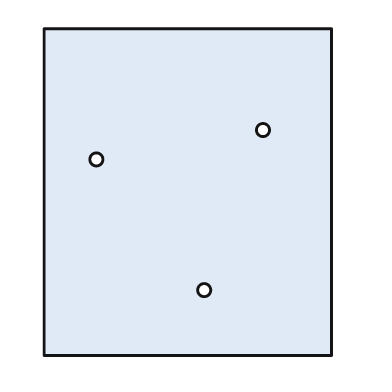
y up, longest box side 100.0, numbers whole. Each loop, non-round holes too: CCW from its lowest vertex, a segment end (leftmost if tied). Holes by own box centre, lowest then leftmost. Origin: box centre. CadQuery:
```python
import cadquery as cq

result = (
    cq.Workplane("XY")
    .moveTo(-44.0, -50.0)
    .lineTo(44.0, -50.0)
    .lineTo(44.0, 50.0)
    .lineTo(-44.0, 50.0)
    .close()
    .moveTo(5.0, -30.0)
    .circle(2.0)
    .moveTo(-28.0, 10.0)
    .circle(2.0)
    .moveTo(23.0, 19.0)
    .circle(2.0)
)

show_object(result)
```